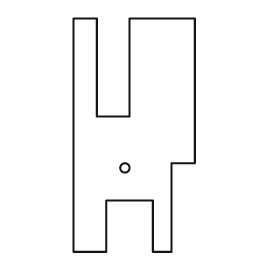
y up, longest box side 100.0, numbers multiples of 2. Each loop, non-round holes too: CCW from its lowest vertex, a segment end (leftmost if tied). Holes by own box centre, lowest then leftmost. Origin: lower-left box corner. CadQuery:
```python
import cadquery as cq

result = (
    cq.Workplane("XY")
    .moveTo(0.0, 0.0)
    .lineTo(14.0, 0.0)
    .lineTo(14.0, 22.0)
    .lineTo(34.0, 22.0)
    .lineTo(34.0, 0.0)
    .lineTo(42.0, 0.0)
    .lineTo(42.0, 38.0)
    .lineTo(52.0, 38.0)
    .lineTo(52.0, 100.0)
    .lineTo(24.0, 100.0)
    .lineTo(24.0, 58.0)
    .lineTo(10.0, 58.0)
    .lineTo(10.0, 100.0)
    .lineTo(0.0, 100.0)
    .close()
    .moveTo(22.0, 36.0)
    .circle(2.0)
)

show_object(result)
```